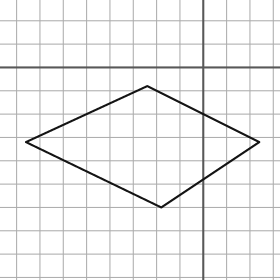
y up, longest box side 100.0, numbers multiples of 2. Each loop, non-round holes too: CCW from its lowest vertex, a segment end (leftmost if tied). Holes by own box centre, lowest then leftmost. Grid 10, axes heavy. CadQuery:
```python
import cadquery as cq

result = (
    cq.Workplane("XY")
    .moveTo(-18.0, -60.0)
    .lineTo(24.0, -32.0)
    .lineTo(-24.0, -8.0)
    .lineTo(-76.0, -32.0)
    .close()
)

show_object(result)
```